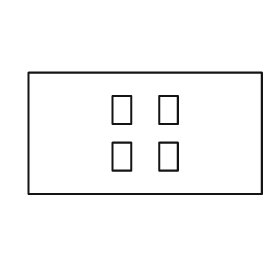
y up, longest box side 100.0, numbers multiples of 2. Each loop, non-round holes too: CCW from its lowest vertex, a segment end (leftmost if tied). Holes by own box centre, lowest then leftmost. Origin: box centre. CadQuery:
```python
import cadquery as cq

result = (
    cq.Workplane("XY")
    .moveTo(-50.0, -26.0)
    .lineTo(50.0, -26.0)
    .lineTo(50.0, 26.0)
    .lineTo(-50.0, 26.0)
    .close()
    .moveTo(-14.0, -16.0)
    .lineTo(-6.0, -16.0)
    .lineTo(-6.0, -4.0)
    .lineTo(-14.0, -4.0)
    .close()
    .moveTo(6.0, -16.0)
    .lineTo(14.0, -16.0)
    .lineTo(14.0, -4.0)
    .lineTo(6.0, -4.0)
    .close()
    .moveTo(-14.0, 4.0)
    .lineTo(-6.0, 4.0)
    .lineTo(-6.0, 16.0)
    .lineTo(-14.0, 16.0)
    .close()
    .moveTo(6.0, 4.0)
    .lineTo(14.0, 4.0)
    .lineTo(14.0, 16.0)
    .lineTo(6.0, 16.0)
    .close()
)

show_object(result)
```